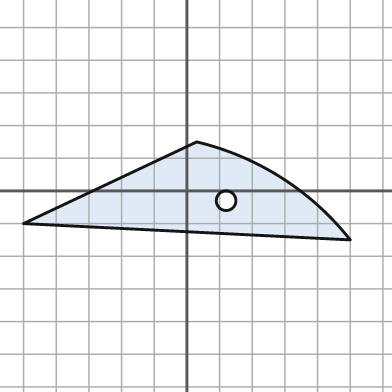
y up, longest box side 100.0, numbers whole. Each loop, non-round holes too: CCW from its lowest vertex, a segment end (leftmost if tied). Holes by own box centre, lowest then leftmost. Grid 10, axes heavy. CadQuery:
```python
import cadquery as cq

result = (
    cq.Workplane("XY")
    .moveTo(50.0, -15.0)
    .threePointArc((29.0, 4.0), (3.0, 15.0))
    .lineTo(-50.0, -10.0)
    .close()
    .moveTo(12.0, -3.0)
    .circle(3.0)
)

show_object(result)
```